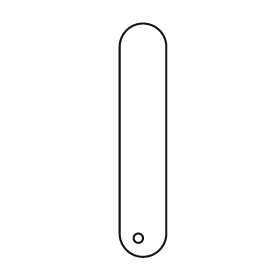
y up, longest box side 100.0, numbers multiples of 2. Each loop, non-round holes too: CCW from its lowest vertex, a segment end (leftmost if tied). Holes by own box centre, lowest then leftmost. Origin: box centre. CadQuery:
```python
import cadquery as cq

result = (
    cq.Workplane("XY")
    .moveTo(-10.0, -40.0)
    .threePointArc((0.0, -50.0), (10.0, -40.0))
    .lineTo(10.0, 40.0)
    .threePointArc((0.0, 50.0), (-10.0, 40.0))
    .close()
    .moveTo(-2.0, -42.0)
    .circle(2.0)
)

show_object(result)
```